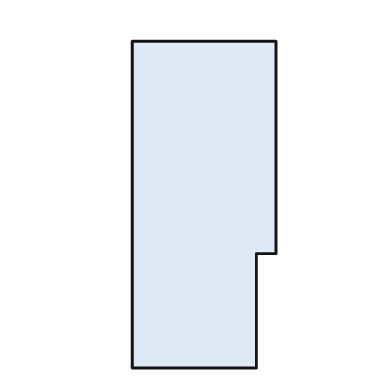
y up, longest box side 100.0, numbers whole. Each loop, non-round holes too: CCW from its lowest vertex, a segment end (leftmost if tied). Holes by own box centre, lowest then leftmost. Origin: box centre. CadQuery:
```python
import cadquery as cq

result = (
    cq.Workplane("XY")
    .moveTo(-22.0, -50.0)
    .lineTo(16.0, -50.0)
    .lineTo(16.0, -15.0)
    .lineTo(22.0, -15.0)
    .lineTo(22.0, 50.0)
    .lineTo(-22.0, 50.0)
    .close()
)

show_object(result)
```